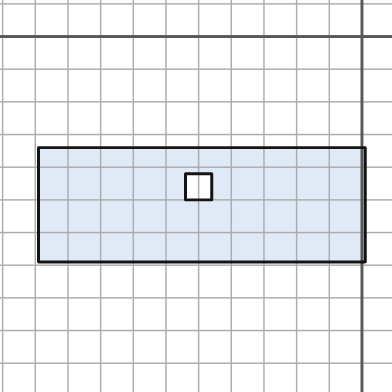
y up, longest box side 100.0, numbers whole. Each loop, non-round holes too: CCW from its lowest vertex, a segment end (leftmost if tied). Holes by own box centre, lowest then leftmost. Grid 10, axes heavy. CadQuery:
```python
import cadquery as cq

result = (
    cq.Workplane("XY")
    .moveTo(-99.0, -69.0)
    .lineTo(1.0, -69.0)
    .lineTo(1.0, -34.0)
    .lineTo(-99.0, -34.0)
    .close()
    .moveTo(-54.0, -50.0)
    .lineTo(-46.0, -50.0)
    .lineTo(-46.0, -42.0)
    .lineTo(-54.0, -42.0)
    .close()
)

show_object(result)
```